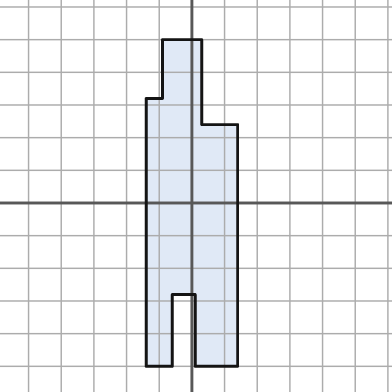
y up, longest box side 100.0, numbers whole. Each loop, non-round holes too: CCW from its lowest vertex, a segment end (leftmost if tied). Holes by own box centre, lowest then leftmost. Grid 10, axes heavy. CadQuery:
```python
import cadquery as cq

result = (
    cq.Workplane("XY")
    .moveTo(-14.0, -50.0)
    .lineTo(-6.0, -50.0)
    .lineTo(-6.0, -28.0)
    .lineTo(1.0, -28.0)
    .lineTo(1.0, -50.0)
    .lineTo(14.0, -50.0)
    .lineTo(14.0, 24.0)
    .lineTo(3.0, 24.0)
    .lineTo(3.0, 50.0)
    .lineTo(-9.0, 50.0)
    .lineTo(-9.0, 32.0)
    .lineTo(-14.0, 32.0)
    .close()
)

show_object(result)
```